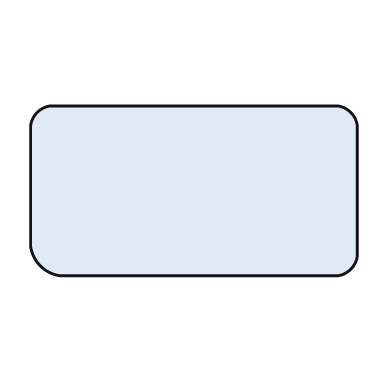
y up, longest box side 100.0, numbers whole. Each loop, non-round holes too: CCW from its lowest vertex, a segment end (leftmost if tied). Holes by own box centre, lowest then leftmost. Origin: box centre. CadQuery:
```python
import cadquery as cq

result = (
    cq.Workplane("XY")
    .moveTo(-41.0, -26.0)
    .lineTo(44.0, -26.0)
    .threePointArc((48.0, -24.0), (50.0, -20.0))
    .lineTo(50.0, 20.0)
    .threePointArc((48.0, 24.0), (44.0, 26.0))
    .lineTo(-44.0, 26.0)
    .threePointArc((-48.0, 24.0), (-50.0, 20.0))
    .lineTo(-50.0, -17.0)
    .threePointArc((-47.0, -23.0), (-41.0, -26.0))
    .close()
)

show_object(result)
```